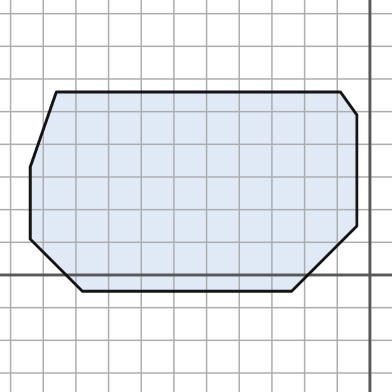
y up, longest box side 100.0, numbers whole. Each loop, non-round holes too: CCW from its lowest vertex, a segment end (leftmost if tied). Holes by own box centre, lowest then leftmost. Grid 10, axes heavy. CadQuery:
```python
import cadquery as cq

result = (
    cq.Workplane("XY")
    .moveTo(-88.0, -5.0)
    .lineTo(-24.0, -5.0)
    .lineTo(-4.0, 15.0)
    .lineTo(-4.0, 49.0)
    .lineTo(-9.0, 56.0)
    .lineTo(-96.0, 56.0)
    .lineTo(-104.0, 33.0)
    .lineTo(-104.0, 11.0)
    .close()
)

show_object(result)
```